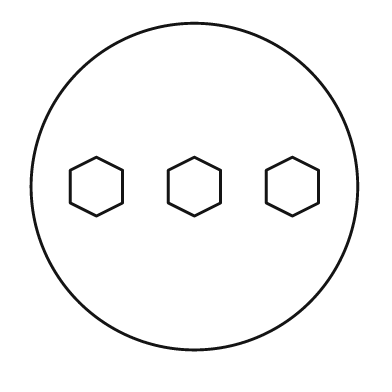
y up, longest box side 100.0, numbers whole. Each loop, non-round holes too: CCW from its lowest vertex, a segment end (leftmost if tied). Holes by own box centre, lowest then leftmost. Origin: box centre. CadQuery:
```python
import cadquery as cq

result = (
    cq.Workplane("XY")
    .moveTo(0.0, 0.0)
    .circle(50.0)
    .moveTo(-30.0, -9.0)
    .lineTo(-22.0, -5.0)
    .lineTo(-22.0, 5.0)
    .lineTo(-30.0, 9.0)
    .lineTo(-38.0, 5.0)
    .lineTo(-38.0, -5.0)
    .close()
    .moveTo(0.0, -9.0)
    .lineTo(8.0, -5.0)
    .lineTo(8.0, 5.0)
    .lineTo(0.0, 9.0)
    .lineTo(-8.0, 5.0)
    .lineTo(-8.0, -5.0)
    .close()
    .moveTo(30.0, -9.0)
    .lineTo(38.0, -5.0)
    .lineTo(38.0, 5.0)
    .lineTo(30.0, 9.0)
    .lineTo(22.0, 5.0)
    .lineTo(22.0, -5.0)
    .close()
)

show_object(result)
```